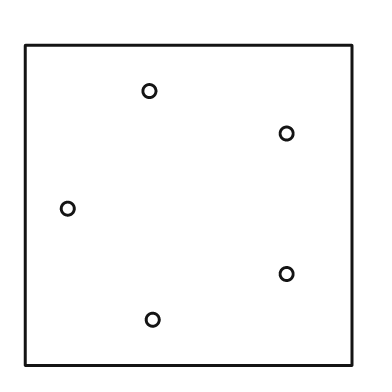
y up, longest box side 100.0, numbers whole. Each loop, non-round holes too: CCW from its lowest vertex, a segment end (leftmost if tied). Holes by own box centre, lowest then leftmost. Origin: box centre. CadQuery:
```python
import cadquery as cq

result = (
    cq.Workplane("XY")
    .moveTo(-50.0, -49.0)
    .lineTo(50.0, -49.0)
    .lineTo(50.0, 49.0)
    .lineTo(-50.0, 49.0)
    .close()
    .moveTo(-11.0, -35.0)
    .circle(2.0)
    .moveTo(30.0, -21.0)
    .circle(2.0)
    .moveTo(-37.0, -1.0)
    .circle(2.0)
    .moveTo(30.0, 22.0)
    .circle(2.0)
    .moveTo(-12.0, 35.0)
    .circle(2.0)
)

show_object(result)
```